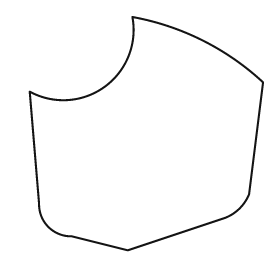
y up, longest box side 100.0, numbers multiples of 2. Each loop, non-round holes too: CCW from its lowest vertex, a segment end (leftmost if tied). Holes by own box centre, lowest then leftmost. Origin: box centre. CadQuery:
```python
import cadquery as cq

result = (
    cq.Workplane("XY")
    .moveTo(-8.0, -50.0)
    .lineTo(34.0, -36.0)
    .threePointArc((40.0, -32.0), (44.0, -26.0))
    .lineTo(50.0, 22.0)
    .threePointArc((24.0, 40.0), (-6.0, 50.0))
    .threePointArc((-18.0, 20.0), (-50.0, 18.0))
    .lineTo(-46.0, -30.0)
    .threePointArc((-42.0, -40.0), (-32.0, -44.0))
    .close()
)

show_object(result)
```